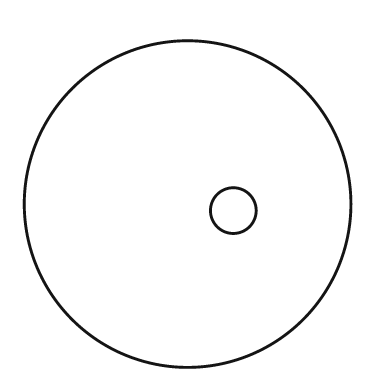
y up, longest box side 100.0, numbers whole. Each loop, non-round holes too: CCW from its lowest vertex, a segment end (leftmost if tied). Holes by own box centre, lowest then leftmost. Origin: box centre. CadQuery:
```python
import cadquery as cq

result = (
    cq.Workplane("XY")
    .moveTo(0.0, 0.0)
    .circle(50.0)
    .moveTo(14.0, -2.0)
    .circle(7.0)
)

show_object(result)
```